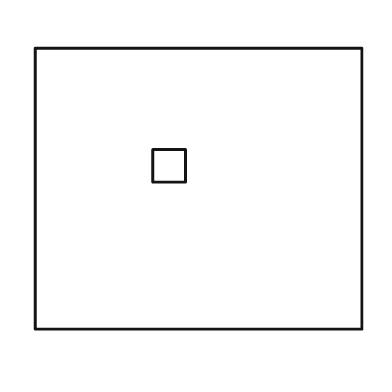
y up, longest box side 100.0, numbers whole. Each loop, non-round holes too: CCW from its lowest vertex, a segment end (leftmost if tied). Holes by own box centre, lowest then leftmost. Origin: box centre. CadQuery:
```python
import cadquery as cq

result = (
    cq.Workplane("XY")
    .moveTo(-50.0, -43.0)
    .lineTo(50.0, -43.0)
    .lineTo(50.0, 43.0)
    .lineTo(-50.0, 43.0)
    .close()
    .moveTo(-14.0, 2.0)
    .lineTo(-4.0, 2.0)
    .lineTo(-4.0, 12.0)
    .lineTo(-14.0, 12.0)
    .close()
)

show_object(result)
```